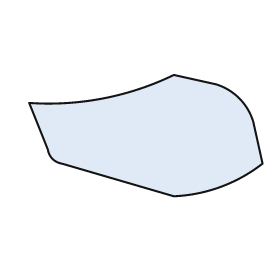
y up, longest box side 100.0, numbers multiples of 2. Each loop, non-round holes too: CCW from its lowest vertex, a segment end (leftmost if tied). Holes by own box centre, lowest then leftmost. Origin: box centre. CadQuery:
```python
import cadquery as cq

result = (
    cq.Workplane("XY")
    .moveTo(12.0, -26.0)
    .threePointArc((32.0, -22.0), (50.0, -12.0))
    .lineTo(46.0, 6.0)
    .threePointArc((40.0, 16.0), (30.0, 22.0))
    .lineTo(12.0, 26.0)
    .threePointArc((-18.0, 16.0), (-50.0, 14.0))
    .lineTo(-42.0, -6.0)
    .threePointArc((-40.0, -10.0), (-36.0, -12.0))
    .close()
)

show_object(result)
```